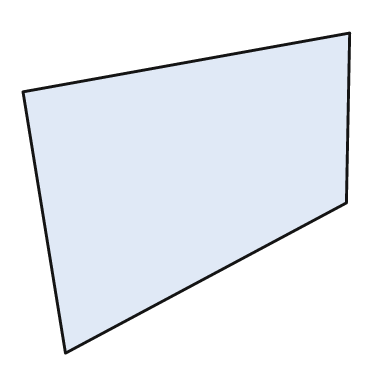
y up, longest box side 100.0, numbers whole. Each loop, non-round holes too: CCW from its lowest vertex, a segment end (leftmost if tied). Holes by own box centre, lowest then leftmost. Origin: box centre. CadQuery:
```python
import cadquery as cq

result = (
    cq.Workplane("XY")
    .moveTo(-37.0, -49.0)
    .lineTo(49.0, -3.0)
    .lineTo(50.0, 49.0)
    .lineTo(-50.0, 31.0)
    .close()
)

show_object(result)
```